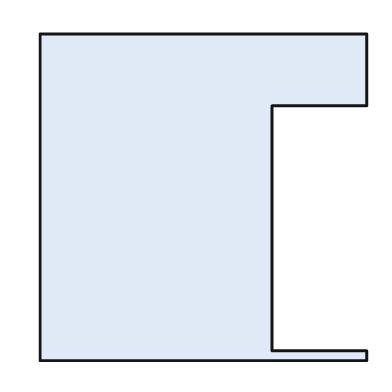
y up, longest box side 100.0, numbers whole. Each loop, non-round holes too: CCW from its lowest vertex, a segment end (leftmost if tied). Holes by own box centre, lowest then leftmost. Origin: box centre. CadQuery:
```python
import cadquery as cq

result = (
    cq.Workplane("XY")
    .moveTo(-50.0, -50.0)
    .lineTo(50.0, -50.0)
    .lineTo(50.0, -47.0)
    .lineTo(21.0, -47.0)
    .lineTo(21.0, 28.0)
    .lineTo(50.0, 28.0)
    .lineTo(50.0, 50.0)
    .lineTo(-50.0, 50.0)
    .close()
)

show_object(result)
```